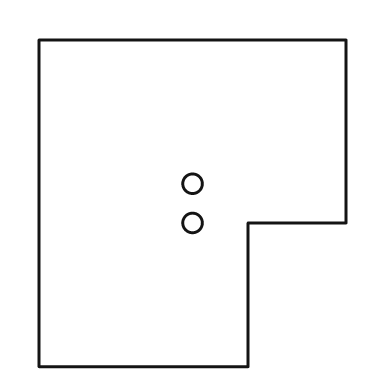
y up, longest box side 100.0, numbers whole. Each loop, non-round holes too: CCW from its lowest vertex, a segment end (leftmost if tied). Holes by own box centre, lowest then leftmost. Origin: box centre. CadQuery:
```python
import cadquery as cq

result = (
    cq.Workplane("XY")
    .moveTo(-47.0, -50.0)
    .lineTo(17.0, -50.0)
    .lineTo(17.0, -6.0)
    .lineTo(47.0, -6.0)
    .lineTo(47.0, 50.0)
    .lineTo(-47.0, 50.0)
    .close()
    .moveTo(0.0, -6.0)
    .circle(3.0)
    .moveTo(0.0, 6.0)
    .circle(3.0)
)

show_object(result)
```